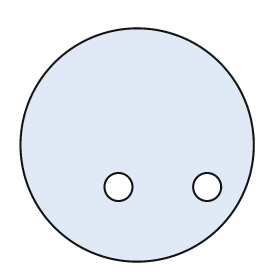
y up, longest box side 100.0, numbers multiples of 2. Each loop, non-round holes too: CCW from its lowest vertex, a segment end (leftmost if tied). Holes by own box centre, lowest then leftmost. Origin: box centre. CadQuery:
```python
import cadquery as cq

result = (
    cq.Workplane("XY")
    .moveTo(0.0, 0.0)
    .circle(50.0)
    .moveTo(-8.0, -18.0)
    .circle(6.0)
    .moveTo(30.0, -18.0)
    .circle(6.0)
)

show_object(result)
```